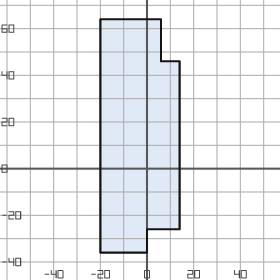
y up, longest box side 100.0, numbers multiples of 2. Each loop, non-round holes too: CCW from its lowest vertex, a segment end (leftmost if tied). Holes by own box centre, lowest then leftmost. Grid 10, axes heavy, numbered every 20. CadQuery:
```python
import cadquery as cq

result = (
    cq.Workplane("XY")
    .moveTo(-20.0, -36.0)
    .lineTo(0.0, -36.0)
    .lineTo(0.0, -26.0)
    .lineTo(14.0, -26.0)
    .lineTo(14.0, 46.0)
    .lineTo(6.0, 46.0)
    .lineTo(6.0, 64.0)
    .lineTo(-20.0, 64.0)
    .close()
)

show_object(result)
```